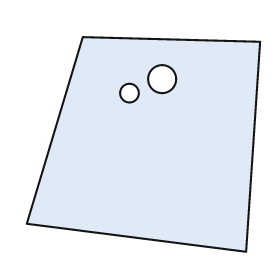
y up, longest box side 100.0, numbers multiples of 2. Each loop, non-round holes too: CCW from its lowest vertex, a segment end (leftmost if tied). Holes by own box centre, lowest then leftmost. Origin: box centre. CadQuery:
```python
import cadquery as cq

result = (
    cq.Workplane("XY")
    .moveTo(44.0, -46.0)
    .lineTo(50.0, 44.0)
    .lineTo(-26.0, 46.0)
    .lineTo(-50.0, -34.0)
    .close()
    .moveTo(-6.0, 22.0)
    .circle(4.0)
    .moveTo(8.0, 28.0)
    .circle(6.0)
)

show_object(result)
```